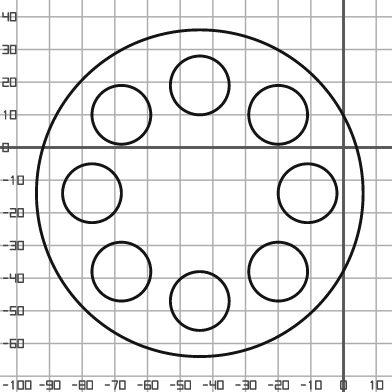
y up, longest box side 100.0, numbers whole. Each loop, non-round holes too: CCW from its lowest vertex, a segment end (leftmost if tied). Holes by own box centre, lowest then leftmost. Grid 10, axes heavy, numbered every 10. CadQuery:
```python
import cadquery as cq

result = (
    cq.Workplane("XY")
    .moveTo(-44.0, -14.0)
    .circle(50.0)
    .moveTo(-44.0, -47.0)
    .circle(9.0)
    .moveTo(-68.0, -38.0)
    .circle(9.0)
    .moveTo(-20.0, -38.0)
    .circle(9.0)
    .moveTo(-77.0, -14.0)
    .circle(9.0)
    .moveTo(-11.0, -14.0)
    .circle(9.0)
    .moveTo(-68.0, 10.0)
    .circle(9.0)
    .moveTo(-20.0, 10.0)
    .circle(9.0)
    .moveTo(-44.0, 19.0)
    .circle(9.0)
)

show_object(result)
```